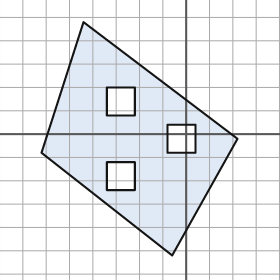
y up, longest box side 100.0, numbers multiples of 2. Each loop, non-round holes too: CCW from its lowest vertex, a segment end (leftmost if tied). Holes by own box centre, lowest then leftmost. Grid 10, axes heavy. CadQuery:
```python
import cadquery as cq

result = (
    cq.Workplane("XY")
    .moveTo(-6.0, -52.0)
    .lineTo(22.0, -2.0)
    .lineTo(-44.0, 48.0)
    .lineTo(-62.0, -8.0)
    .close()
    .moveTo(-34.0, -24.0)
    .lineTo(-22.0, -24.0)
    .lineTo(-22.0, -12.0)
    .lineTo(-34.0, -12.0)
    .close()
    .moveTo(-8.0, -8.0)
    .lineTo(4.0, -8.0)
    .lineTo(4.0, 4.0)
    .lineTo(-8.0, 4.0)
    .close()
    .moveTo(-34.0, 8.0)
    .lineTo(-22.0, 8.0)
    .lineTo(-22.0, 20.0)
    .lineTo(-34.0, 20.0)
    .close()
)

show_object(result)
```